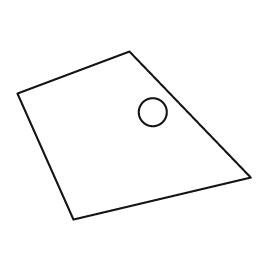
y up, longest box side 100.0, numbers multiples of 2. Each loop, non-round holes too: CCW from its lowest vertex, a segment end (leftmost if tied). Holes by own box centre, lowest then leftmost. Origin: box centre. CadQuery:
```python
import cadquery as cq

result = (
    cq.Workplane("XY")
    .moveTo(-26.0, -36.0)
    .lineTo(50.0, -18.0)
    .lineTo(-2.0, 36.0)
    .lineTo(-50.0, 18.0)
    .close()
    .moveTo(8.0, 10.0)
    .circle(6.0)
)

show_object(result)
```